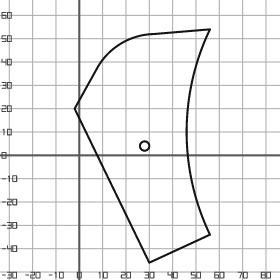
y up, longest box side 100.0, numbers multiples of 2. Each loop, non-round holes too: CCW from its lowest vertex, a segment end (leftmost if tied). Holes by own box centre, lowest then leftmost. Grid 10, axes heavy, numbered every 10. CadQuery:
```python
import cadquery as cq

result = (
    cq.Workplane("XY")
    .moveTo(30.0, -46.0)
    .lineTo(56.0, -34.0)
    .threePointArc((46.0, 10.0), (56.0, 54.0))
    .lineTo(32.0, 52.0)
    .threePointArc((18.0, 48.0), (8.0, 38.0))
    .lineTo(-2.0, 20.0)
    .close()
    .moveTo(28.0, 4.0)
    .circle(2.0)
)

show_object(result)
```